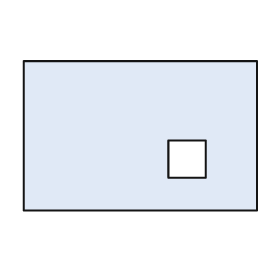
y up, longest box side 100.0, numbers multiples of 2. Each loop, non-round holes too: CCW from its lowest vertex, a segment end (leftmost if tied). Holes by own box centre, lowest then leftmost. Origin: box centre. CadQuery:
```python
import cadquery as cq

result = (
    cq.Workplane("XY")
    .moveTo(-50.0, -32.0)
    .lineTo(50.0, -32.0)
    .lineTo(50.0, 32.0)
    .lineTo(-50.0, 32.0)
    .close()
    .moveTo(12.0, -18.0)
    .lineTo(28.0, -18.0)
    .lineTo(28.0, -2.0)
    .lineTo(12.0, -2.0)
    .close()
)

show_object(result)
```